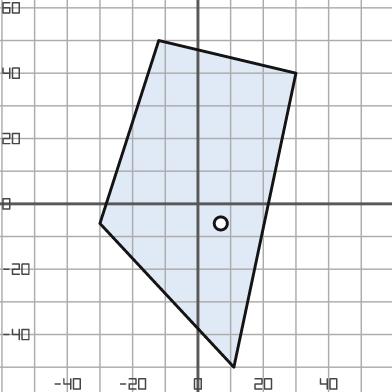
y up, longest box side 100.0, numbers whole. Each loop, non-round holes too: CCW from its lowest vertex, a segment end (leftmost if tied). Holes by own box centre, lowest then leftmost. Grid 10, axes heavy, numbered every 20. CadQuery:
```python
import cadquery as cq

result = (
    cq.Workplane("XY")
    .moveTo(11.0, -50.0)
    .lineTo(30.0, 40.0)
    .lineTo(-12.0, 50.0)
    .lineTo(-30.0, -6.0)
    .close()
    .moveTo(7.0, -6.0)
    .circle(2.0)
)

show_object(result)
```